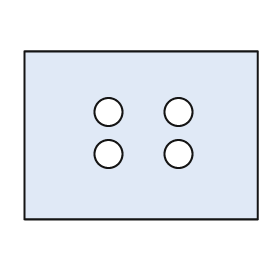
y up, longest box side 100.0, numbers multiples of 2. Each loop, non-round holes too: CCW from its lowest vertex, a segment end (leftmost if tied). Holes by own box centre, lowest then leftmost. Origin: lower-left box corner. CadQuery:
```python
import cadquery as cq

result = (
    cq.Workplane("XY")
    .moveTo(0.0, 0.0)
    .lineTo(100.0, 0.0)
    .lineTo(100.0, 72.0)
    .lineTo(0.0, 72.0)
    .close()
    .moveTo(36.0, 28.0)
    .circle(6.0)
    .moveTo(66.0, 28.0)
    .circle(6.0)
    .moveTo(36.0, 46.0)
    .circle(6.0)
    .moveTo(66.0, 46.0)
    .circle(6.0)
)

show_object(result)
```